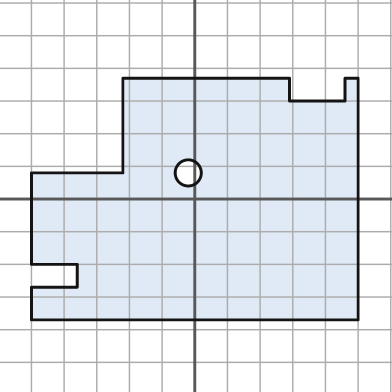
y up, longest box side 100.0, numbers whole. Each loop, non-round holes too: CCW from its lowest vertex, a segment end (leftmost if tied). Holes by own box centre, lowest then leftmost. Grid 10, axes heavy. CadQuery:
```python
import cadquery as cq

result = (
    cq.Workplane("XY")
    .moveTo(-50.0, -37.0)
    .lineTo(50.0, -37.0)
    .lineTo(50.0, 37.0)
    .lineTo(46.0, 37.0)
    .lineTo(46.0, 30.0)
    .lineTo(29.0, 30.0)
    .lineTo(29.0, 37.0)
    .lineTo(-22.0, 37.0)
    .lineTo(-22.0, 8.0)
    .lineTo(-50.0, 8.0)
    .lineTo(-50.0, -20.0)
    .lineTo(-36.0, -20.0)
    .lineTo(-36.0, -27.0)
    .lineTo(-50.0, -27.0)
    .close()
    .moveTo(-2.0, 8.0)
    .circle(4.0)
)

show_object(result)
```